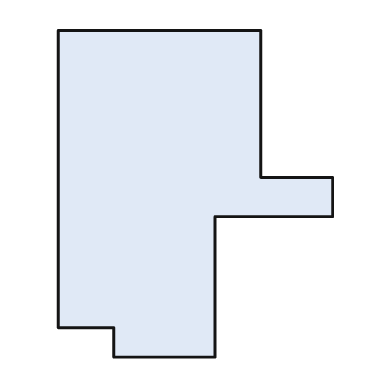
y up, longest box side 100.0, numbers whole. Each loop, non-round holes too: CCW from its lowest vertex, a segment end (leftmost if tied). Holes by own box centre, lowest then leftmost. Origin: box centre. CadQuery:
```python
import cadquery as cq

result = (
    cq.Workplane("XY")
    .moveTo(-25.0, -50.0)
    .lineTo(6.0, -50.0)
    .lineTo(6.0, -7.0)
    .lineTo(42.0, -7.0)
    .lineTo(42.0, 5.0)
    .lineTo(20.0, 5.0)
    .lineTo(20.0, 50.0)
    .lineTo(-42.0, 50.0)
    .lineTo(-42.0, -41.0)
    .lineTo(-25.0, -41.0)
    .close()
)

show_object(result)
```